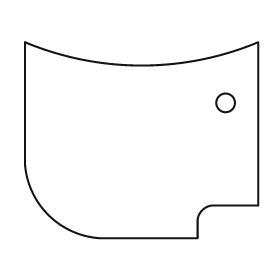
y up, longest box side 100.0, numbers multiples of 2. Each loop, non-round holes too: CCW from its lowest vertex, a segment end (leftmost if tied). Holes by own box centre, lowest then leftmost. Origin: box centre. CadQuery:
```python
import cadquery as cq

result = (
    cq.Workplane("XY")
    .moveTo(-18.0, -42.0)
    .lineTo(24.0, -42.0)
    .lineTo(24.0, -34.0)
    .threePointArc((26.0, -30.0), (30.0, -28.0))
    .lineTo(50.0, -28.0)
    .lineTo(50.0, 42.0)
    .threePointArc((0.0, 32.0), (-50.0, 42.0))
    .lineTo(-50.0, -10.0)
    .threePointArc((-40.0, -32.0), (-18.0, -42.0))
    .close()
    .moveTo(36.0, 16.0)
    .circle(4.0)
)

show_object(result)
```